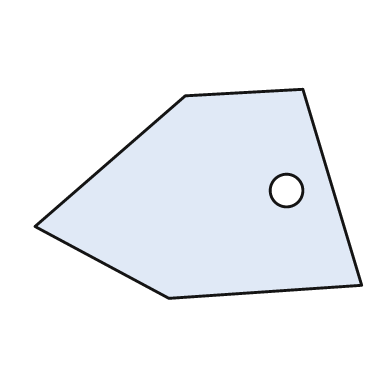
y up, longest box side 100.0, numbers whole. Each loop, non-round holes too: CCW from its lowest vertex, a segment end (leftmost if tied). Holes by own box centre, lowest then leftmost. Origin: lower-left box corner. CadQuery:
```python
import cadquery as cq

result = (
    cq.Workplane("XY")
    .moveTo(41.0, 0.0)
    .lineTo(100.0, 4.0)
    .lineTo(82.0, 64.0)
    .lineTo(46.0, 62.0)
    .lineTo(0.0, 22.0)
    .close()
    .moveTo(77.0, 33.0)
    .circle(5.0)
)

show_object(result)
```